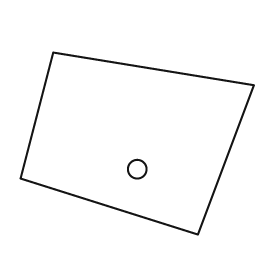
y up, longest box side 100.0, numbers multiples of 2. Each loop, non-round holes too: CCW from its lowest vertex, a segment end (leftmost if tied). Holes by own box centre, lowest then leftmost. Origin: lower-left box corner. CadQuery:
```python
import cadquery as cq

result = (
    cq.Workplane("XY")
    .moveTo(76.0, 0.0)
    .lineTo(100.0, 64.0)
    .lineTo(14.0, 78.0)
    .lineTo(0.0, 24.0)
    .close()
    .moveTo(50.0, 28.0)
    .circle(4.0)
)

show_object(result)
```